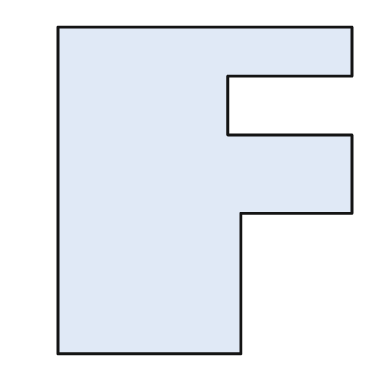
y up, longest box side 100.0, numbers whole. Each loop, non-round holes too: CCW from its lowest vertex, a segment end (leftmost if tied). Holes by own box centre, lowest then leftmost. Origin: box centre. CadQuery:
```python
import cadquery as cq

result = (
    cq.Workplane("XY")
    .moveTo(-45.0, -50.0)
    .lineTo(11.0, -50.0)
    .lineTo(11.0, -7.0)
    .lineTo(45.0, -7.0)
    .lineTo(45.0, 17.0)
    .lineTo(7.0, 17.0)
    .lineTo(7.0, 35.0)
    .lineTo(45.0, 35.0)
    .lineTo(45.0, 50.0)
    .lineTo(-45.0, 50.0)
    .close()
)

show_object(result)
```